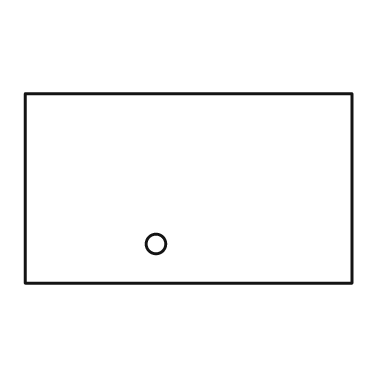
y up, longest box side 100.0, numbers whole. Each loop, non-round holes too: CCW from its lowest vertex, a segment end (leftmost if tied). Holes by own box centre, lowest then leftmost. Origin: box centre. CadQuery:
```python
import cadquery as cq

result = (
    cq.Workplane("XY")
    .moveTo(-50.0, -29.0)
    .lineTo(50.0, -29.0)
    .lineTo(50.0, 29.0)
    .lineTo(-50.0, 29.0)
    .close()
    .moveTo(-10.0, -17.0)
    .circle(3.0)
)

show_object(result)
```